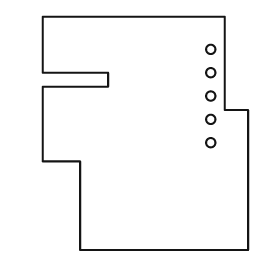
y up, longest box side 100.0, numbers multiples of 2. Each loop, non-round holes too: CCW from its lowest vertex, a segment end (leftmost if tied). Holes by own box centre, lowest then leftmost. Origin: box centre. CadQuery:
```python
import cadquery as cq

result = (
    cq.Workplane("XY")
    .moveTo(-28.0, -50.0)
    .lineTo(44.0, -50.0)
    .lineTo(44.0, 10.0)
    .lineTo(34.0, 10.0)
    .lineTo(34.0, 50.0)
    .lineTo(-44.0, 50.0)
    .lineTo(-44.0, 26.0)
    .lineTo(-16.0, 26.0)
    .lineTo(-16.0, 20.0)
    .lineTo(-44.0, 20.0)
    .lineTo(-44.0, -12.0)
    .lineTo(-28.0, -12.0)
    .close()
    .moveTo(28.0, -4.0)
    .circle(2.0)
    .moveTo(28.0, 6.0)
    .circle(2.0)
    .moveTo(28.0, 16.0)
    .circle(2.0)
    .moveTo(28.0, 26.0)
    .circle(2.0)
    .moveTo(28.0, 36.0)
    .circle(2.0)
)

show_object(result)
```